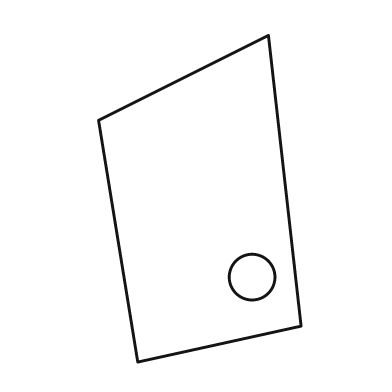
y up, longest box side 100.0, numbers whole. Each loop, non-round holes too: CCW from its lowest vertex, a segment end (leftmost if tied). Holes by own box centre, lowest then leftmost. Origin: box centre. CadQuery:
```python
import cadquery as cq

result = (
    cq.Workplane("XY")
    .moveTo(-19.0, -50.0)
    .lineTo(31.0, -39.0)
    .lineTo(21.0, 50.0)
    .lineTo(-31.0, 24.0)
    .close()
    .moveTo(16.0, -24.0)
    .circle(7.0)
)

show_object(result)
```